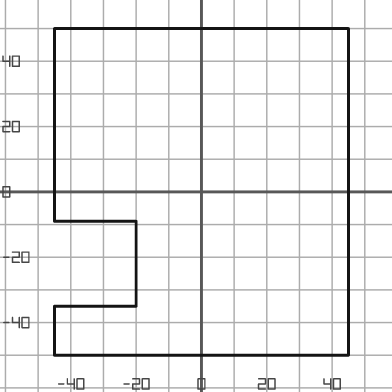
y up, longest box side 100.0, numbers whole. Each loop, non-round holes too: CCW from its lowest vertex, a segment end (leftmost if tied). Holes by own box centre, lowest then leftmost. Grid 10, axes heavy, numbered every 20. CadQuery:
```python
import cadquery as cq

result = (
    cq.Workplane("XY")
    .moveTo(-45.0, -50.0)
    .lineTo(45.0, -50.0)
    .lineTo(45.0, 50.0)
    .lineTo(-45.0, 50.0)
    .lineTo(-45.0, -9.0)
    .lineTo(-20.0, -9.0)
    .lineTo(-20.0, -35.0)
    .lineTo(-45.0, -35.0)
    .close()
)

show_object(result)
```